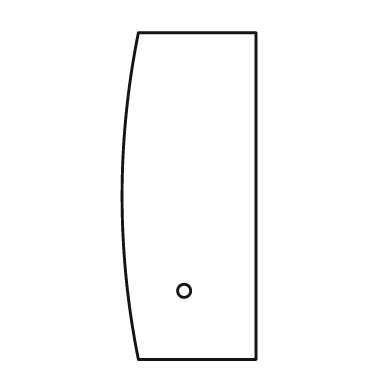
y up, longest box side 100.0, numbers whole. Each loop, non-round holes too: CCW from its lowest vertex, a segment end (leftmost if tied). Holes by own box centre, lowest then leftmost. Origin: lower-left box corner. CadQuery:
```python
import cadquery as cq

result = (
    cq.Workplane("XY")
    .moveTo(5.0, 0.0)
    .lineTo(41.0, 0.0)
    .lineTo(41.0, 100.0)
    .lineTo(5.0, 100.0)
    .threePointArc((0.0, 50.0), (5.0, 0.0))
    .close()
    .moveTo(19.0, 21.0)
    .circle(2.0)
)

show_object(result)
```